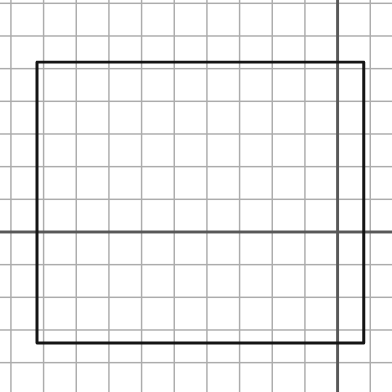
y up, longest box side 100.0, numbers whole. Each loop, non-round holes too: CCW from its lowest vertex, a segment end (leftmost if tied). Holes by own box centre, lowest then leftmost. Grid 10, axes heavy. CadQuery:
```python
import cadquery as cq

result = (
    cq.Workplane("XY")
    .moveTo(-92.0, -34.0)
    .lineTo(8.0, -34.0)
    .lineTo(8.0, 52.0)
    .lineTo(-92.0, 52.0)
    .close()
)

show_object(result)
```